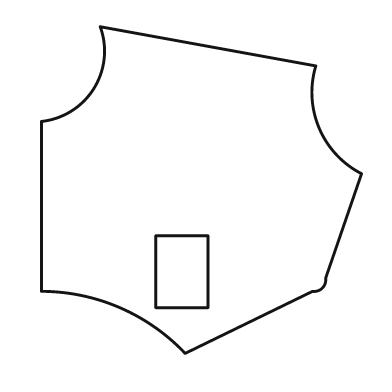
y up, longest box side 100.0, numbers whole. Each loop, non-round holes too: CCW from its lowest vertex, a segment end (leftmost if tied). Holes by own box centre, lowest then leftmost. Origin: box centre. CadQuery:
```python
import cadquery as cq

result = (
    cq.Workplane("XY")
    .moveTo(-5.0, -50.0)
    .lineTo(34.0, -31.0)
    .threePointArc((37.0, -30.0), (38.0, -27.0))
    .lineTo(49.0, 5.0)
    .threePointArc((36.0, 19.0), (35.0, 38.0))
    .lineTo(-31.0, 50.0)
    .threePointArc((-33.0, 31.0), (-49.0, 21.0))
    .lineTo(-49.0, -31.0)
    .threePointArc((-25.0, -36.0), (-5.0, -50.0))
    .close()
    .moveTo(-14.0, -36.0)
    .lineTo(2.0, -36.0)
    .lineTo(2.0, -14.0)
    .lineTo(-14.0, -14.0)
    .close()
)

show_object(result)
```